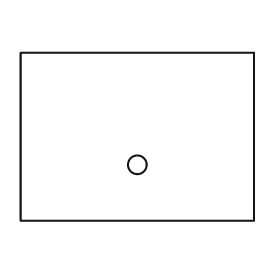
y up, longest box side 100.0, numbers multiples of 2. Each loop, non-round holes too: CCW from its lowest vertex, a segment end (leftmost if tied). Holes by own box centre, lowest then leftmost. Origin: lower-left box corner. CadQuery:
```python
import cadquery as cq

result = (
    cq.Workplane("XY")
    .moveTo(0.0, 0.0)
    .lineTo(100.0, 0.0)
    .lineTo(100.0, 72.0)
    .lineTo(0.0, 72.0)
    .close()
    .moveTo(50.0, 24.0)
    .circle(4.0)
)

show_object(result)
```